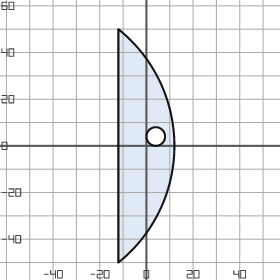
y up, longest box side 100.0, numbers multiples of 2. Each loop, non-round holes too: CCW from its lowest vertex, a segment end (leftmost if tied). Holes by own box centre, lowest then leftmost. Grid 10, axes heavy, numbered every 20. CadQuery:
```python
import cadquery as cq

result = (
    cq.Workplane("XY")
    .moveTo(-12.0, -50.0)
    .threePointArc((12.0, 0.0), (-12.0, 50.0))
    .close()
    .moveTo(4.0, 4.0)
    .circle(4.0)
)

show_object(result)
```